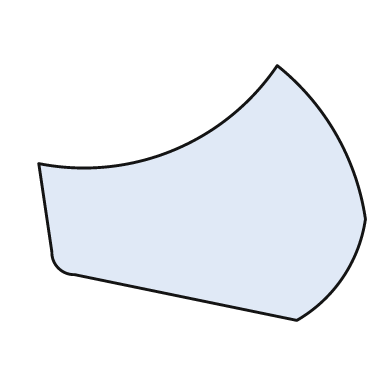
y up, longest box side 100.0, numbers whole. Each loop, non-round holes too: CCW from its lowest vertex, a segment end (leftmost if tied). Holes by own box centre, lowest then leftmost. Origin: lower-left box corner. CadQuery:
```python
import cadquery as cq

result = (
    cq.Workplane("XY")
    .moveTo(79.0, 0.0)
    .threePointArc((93.0, 13.0), (100.0, 31.0))
    .threePointArc((91.0, 57.0), (73.0, 78.0))
    .threePointArc((41.0, 52.0), (0.0, 48.0))
    .lineTo(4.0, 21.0)
    .threePointArc((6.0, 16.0), (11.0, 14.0))
    .close()
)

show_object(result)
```